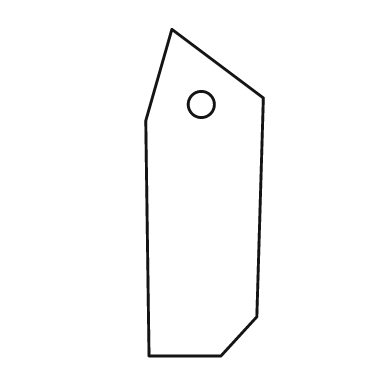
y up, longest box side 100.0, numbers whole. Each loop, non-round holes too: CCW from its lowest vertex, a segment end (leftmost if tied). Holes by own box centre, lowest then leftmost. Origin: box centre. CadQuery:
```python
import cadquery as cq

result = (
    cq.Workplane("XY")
    .moveTo(-17.0, -50.0)
    .lineTo(5.0, -50.0)
    .lineTo(16.0, -38.0)
    .lineTo(18.0, 29.0)
    .lineTo(-10.0, 50.0)
    .lineTo(-18.0, 22.0)
    .close()
    .moveTo(-1.0, 27.0)
    .circle(4.0)
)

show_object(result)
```